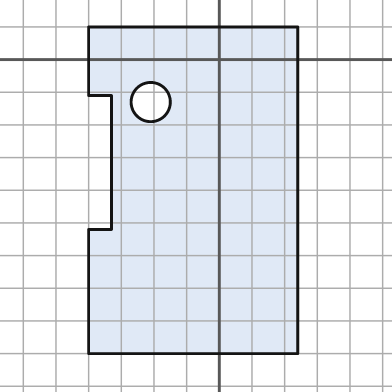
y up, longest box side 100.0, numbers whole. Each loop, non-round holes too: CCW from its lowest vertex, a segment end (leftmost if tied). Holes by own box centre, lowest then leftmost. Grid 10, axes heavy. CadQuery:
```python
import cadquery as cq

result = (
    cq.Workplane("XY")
    .moveTo(-40.0, -90.0)
    .lineTo(24.0, -90.0)
    .lineTo(24.0, 10.0)
    .lineTo(-40.0, 10.0)
    .lineTo(-40.0, -11.0)
    .lineTo(-33.0, -11.0)
    .lineTo(-33.0, -52.0)
    .lineTo(-40.0, -52.0)
    .close()
    .moveTo(-21.0, -13.0)
    .circle(6.0)
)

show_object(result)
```